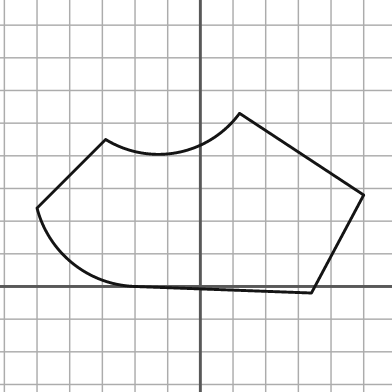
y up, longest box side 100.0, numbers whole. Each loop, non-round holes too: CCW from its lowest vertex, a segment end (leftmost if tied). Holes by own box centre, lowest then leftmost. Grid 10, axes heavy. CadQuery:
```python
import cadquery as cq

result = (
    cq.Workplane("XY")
    .moveTo(34.0, -2.0)
    .lineTo(50.0, 28.0)
    .lineTo(12.0, 53.0)
    .threePointArc((-7.0, 41.0), (-29.0, 45.0))
    .lineTo(-50.0, 24.0)
    .threePointArc((-39.0, 7.0), (-20.0, 0.0))
    .close()
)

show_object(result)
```